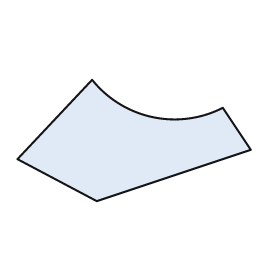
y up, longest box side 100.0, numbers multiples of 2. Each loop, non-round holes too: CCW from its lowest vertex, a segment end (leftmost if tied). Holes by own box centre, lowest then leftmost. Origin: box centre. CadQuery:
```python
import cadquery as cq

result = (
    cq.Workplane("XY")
    .moveTo(-16.0, -26.0)
    .lineTo(50.0, -4.0)
    .lineTo(38.0, 14.0)
    .threePointArc((8.0, 10.0), (-18.0, 26.0))
    .lineTo(-50.0, -8.0)
    .close()
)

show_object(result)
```